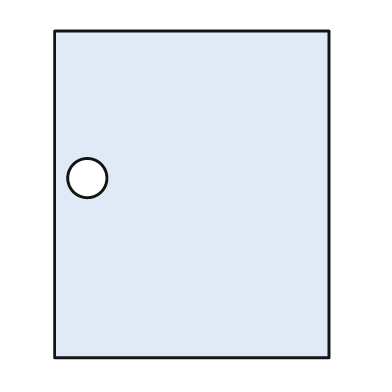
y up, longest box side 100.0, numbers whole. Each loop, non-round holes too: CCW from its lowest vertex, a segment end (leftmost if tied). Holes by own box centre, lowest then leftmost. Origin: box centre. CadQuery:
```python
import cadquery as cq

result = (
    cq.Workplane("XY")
    .moveTo(-42.0, -50.0)
    .lineTo(42.0, -50.0)
    .lineTo(42.0, 50.0)
    .lineTo(-42.0, 50.0)
    .close()
    .moveTo(-32.0, 5.0)
    .circle(6.0)
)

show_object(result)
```